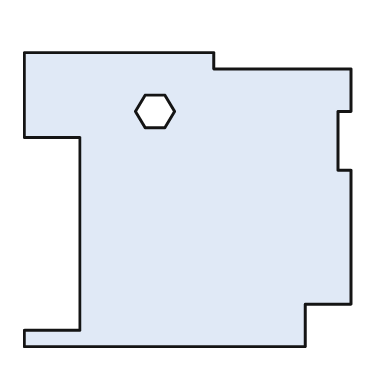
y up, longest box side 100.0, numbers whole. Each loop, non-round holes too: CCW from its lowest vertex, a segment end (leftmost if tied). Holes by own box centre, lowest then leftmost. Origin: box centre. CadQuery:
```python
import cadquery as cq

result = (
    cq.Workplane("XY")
    .moveTo(-50.0, -45.0)
    .lineTo(36.0, -45.0)
    .lineTo(36.0, -32.0)
    .lineTo(50.0, -32.0)
    .lineTo(50.0, 9.0)
    .lineTo(46.0, 9.0)
    .lineTo(46.0, 27.0)
    .lineTo(50.0, 27.0)
    .lineTo(50.0, 40.0)
    .lineTo(8.0, 40.0)
    .lineTo(8.0, 45.0)
    .lineTo(-50.0, 45.0)
    .lineTo(-50.0, 19.0)
    .lineTo(-33.0, 19.0)
    .lineTo(-33.0, -40.0)
    .lineTo(-50.0, -40.0)
    .close()
    .moveTo(-13.0, 22.0)
    .lineTo(-7.0, 22.0)
    .lineTo(-4.0, 27.0)
    .lineTo(-7.0, 32.0)
    .lineTo(-13.0, 32.0)
    .lineTo(-16.0, 27.0)
    .close()
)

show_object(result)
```